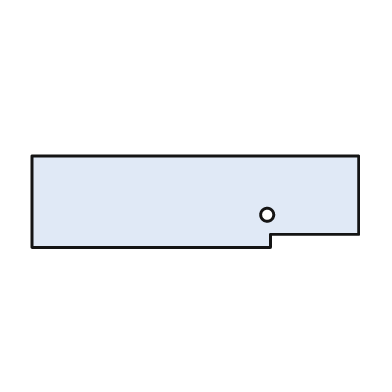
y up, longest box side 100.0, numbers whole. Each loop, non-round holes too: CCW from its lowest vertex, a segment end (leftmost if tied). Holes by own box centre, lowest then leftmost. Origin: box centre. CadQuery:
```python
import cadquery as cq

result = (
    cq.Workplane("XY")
    .moveTo(-50.0, -14.0)
    .lineTo(23.0, -14.0)
    .lineTo(23.0, -10.0)
    .lineTo(50.0, -10.0)
    .lineTo(50.0, 14.0)
    .lineTo(-50.0, 14.0)
    .close()
    .moveTo(22.0, -4.0)
    .circle(2.0)
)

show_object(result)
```